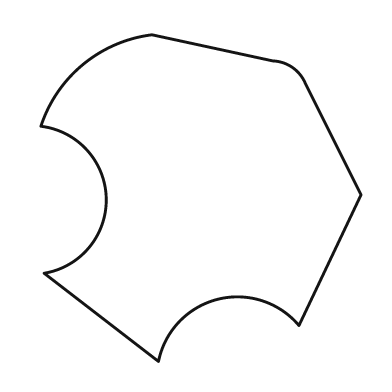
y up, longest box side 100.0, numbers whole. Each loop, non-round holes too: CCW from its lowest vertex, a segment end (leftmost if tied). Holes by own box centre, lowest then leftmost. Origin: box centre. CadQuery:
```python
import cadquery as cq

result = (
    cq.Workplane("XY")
    .moveTo(-13.0, -50.0)
    .threePointArc((5.0, -31.0), (30.0, -39.0))
    .lineTo(49.0, 1.0)
    .lineTo(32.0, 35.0)
    .threePointArc((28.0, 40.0), (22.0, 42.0))
    .lineTo(-15.0, 50.0)
    .threePointArc((-36.0, 41.0), (-49.0, 22.0))
    .threePointArc((-29.0, 0.0), (-48.0, -23.0))
    .close()
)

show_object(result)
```